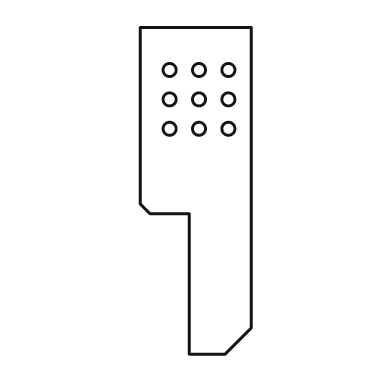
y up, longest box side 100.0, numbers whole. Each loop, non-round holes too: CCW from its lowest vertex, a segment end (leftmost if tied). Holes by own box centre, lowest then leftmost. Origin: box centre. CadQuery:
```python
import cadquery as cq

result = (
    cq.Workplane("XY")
    .moveTo(-2.0, -50.0)
    .lineTo(9.0, -50.0)
    .lineTo(17.0, -42.0)
    .lineTo(17.0, 50.0)
    .lineTo(-17.0, 50.0)
    .lineTo(-17.0, -4.0)
    .lineTo(-14.0, -7.0)
    .lineTo(-2.0, -7.0)
    .close()
    .moveTo(-8.0, 19.0)
    .circle(2.0)
    .moveTo(1.0, 19.0)
    .circle(2.0)
    .moveTo(10.0, 19.0)
    .circle(2.0)
    .moveTo(-8.0, 28.0)
    .circle(2.0)
    .moveTo(1.0, 28.0)
    .circle(2.0)
    .moveTo(10.0, 28.0)
    .circle(2.0)
    .moveTo(-8.0, 37.0)
    .circle(2.0)
    .moveTo(1.0, 37.0)
    .circle(2.0)
    .moveTo(10.0, 37.0)
    .circle(2.0)
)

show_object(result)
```